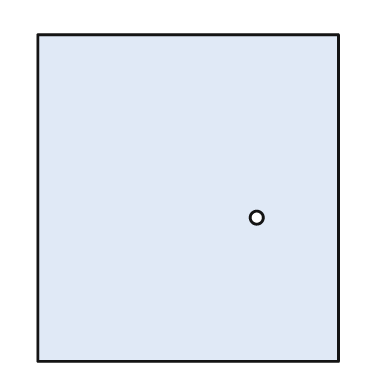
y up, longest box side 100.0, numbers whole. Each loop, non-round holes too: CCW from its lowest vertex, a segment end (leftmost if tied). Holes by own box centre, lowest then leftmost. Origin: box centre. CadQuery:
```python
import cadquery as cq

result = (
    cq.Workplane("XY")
    .moveTo(-46.0, -50.0)
    .lineTo(46.0, -50.0)
    .lineTo(46.0, 50.0)
    .lineTo(-46.0, 50.0)
    .close()
    .moveTo(21.0, -6.0)
    .circle(2.0)
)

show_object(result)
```